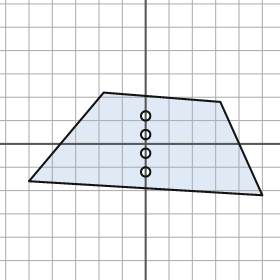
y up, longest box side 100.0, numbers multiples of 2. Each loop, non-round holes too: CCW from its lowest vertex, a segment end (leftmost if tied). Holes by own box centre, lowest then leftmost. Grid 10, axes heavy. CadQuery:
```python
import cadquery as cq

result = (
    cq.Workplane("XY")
    .moveTo(50.0, -22.0)
    .lineTo(32.0, 18.0)
    .lineTo(-18.0, 22.0)
    .lineTo(-50.0, -16.0)
    .close()
    .moveTo(0.0, -12.0)
    .circle(2.0)
    .moveTo(0.0, -4.0)
    .circle(2.0)
    .moveTo(0.0, 4.0)
    .circle(2.0)
    .moveTo(0.0, 12.0)
    .circle(2.0)
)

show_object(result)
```